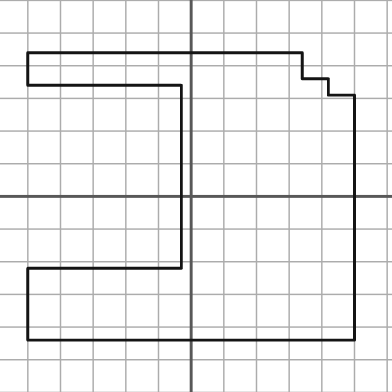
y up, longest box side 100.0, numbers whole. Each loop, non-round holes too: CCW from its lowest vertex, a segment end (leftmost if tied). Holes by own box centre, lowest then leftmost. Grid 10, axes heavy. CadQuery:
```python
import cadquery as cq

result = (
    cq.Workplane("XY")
    .moveTo(-50.0, -44.0)
    .lineTo(50.0, -44.0)
    .lineTo(50.0, 31.0)
    .lineTo(42.0, 31.0)
    .lineTo(42.0, 36.0)
    .lineTo(34.0, 36.0)
    .lineTo(34.0, 44.0)
    .lineTo(-50.0, 44.0)
    .lineTo(-50.0, 34.0)
    .lineTo(-3.0, 34.0)
    .lineTo(-3.0, -22.0)
    .lineTo(-50.0, -22.0)
    .close()
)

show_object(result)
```